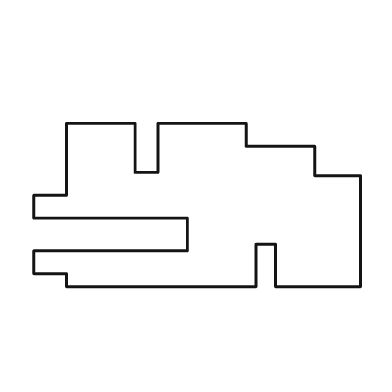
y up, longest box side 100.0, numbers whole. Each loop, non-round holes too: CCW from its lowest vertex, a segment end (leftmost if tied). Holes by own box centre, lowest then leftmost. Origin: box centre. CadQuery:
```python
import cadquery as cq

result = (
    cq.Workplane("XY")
    .moveTo(-40.0, -25.0)
    .lineTo(18.0, -25.0)
    .lineTo(18.0, -12.0)
    .lineTo(24.0, -12.0)
    .lineTo(24.0, -25.0)
    .lineTo(50.0, -25.0)
    .lineTo(50.0, 9.0)
    .lineTo(36.0, 9.0)
    .lineTo(36.0, 18.0)
    .lineTo(15.0, 18.0)
    .lineTo(15.0, 25.0)
    .lineTo(-12.0, 25.0)
    .lineTo(-12.0, 10.0)
    .lineTo(-19.0, 10.0)
    .lineTo(-19.0, 25.0)
    .lineTo(-40.0, 25.0)
    .lineTo(-40.0, 3.0)
    .lineTo(-50.0, 3.0)
    .lineTo(-50.0, -4.0)
    .lineTo(-3.0, -4.0)
    .lineTo(-3.0, -14.0)
    .lineTo(-50.0, -14.0)
    .lineTo(-50.0, -21.0)
    .lineTo(-40.0, -21.0)
    .close()
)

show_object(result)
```